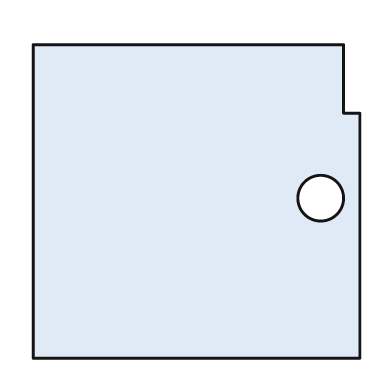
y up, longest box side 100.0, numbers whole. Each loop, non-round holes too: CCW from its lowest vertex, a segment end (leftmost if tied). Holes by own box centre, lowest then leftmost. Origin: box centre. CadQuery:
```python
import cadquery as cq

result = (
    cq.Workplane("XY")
    .moveTo(-50.0, -48.0)
    .lineTo(50.0, -48.0)
    .lineTo(50.0, 27.0)
    .lineTo(45.0, 27.0)
    .lineTo(45.0, 48.0)
    .lineTo(-50.0, 48.0)
    .close()
    .moveTo(38.0, 1.0)
    .circle(7.0)
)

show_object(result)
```